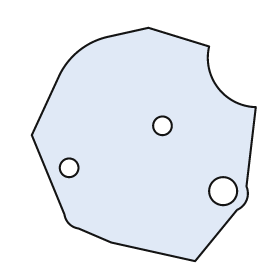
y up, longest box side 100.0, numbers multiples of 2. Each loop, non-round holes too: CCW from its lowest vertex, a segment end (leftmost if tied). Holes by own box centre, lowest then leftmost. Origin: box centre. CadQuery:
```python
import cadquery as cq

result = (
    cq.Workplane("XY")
    .moveTo(22.0, -50.0)
    .lineTo(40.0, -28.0)
    .threePointArc((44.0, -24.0), (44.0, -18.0))
    .lineTo(48.0, 16.0)
    .threePointArc((32.0, 24.0), (28.0, 42.0))
    .lineTo(2.0, 50.0)
    .lineTo(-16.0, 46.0)
    .threePointArc((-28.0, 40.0), (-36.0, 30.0))
    .lineTo(-48.0, 4.0)
    .lineTo(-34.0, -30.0)
    .threePointArc((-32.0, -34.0), (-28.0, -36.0))
    .lineTo(-14.0, -42.0)
    .close()
    .moveTo(34.0, -20.0)
    .circle(6.0)
    .moveTo(-32.0, -10.0)
    .circle(4.0)
    .moveTo(8.0, 8.0)
    .circle(4.0)
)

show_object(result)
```